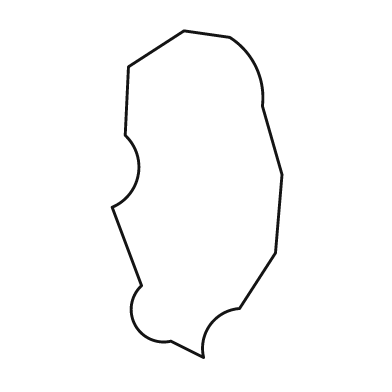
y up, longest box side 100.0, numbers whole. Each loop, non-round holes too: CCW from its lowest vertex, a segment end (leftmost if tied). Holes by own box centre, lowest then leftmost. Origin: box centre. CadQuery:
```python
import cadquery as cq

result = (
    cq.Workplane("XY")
    .moveTo(2.0, -50.0)
    .threePointArc((4.0, -40.0), (13.0, -35.0))
    .lineTo(24.0, -18.0)
    .lineTo(26.0, 6.0)
    .lineTo(20.0, 27.0)
    .threePointArc((18.0, 39.0), (10.0, 48.0))
    .lineTo(-4.0, 50.0)
    .lineTo(-21.0, 39.0)
    .lineTo(-22.0, 18.0)
    .threePointArc((-18.0, 6.0), (-26.0, -4.0))
    .lineTo(-17.0, -28.0)
    .threePointArc((-19.0, -40.0), (-8.0, -45.0))
    .close()
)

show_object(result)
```